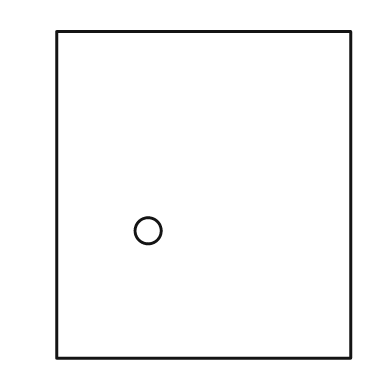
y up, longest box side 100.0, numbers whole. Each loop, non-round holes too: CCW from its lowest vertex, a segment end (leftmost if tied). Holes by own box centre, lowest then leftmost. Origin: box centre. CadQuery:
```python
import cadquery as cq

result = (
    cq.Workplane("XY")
    .moveTo(-45.0, -50.0)
    .lineTo(45.0, -50.0)
    .lineTo(45.0, 50.0)
    .lineTo(-45.0, 50.0)
    .close()
    .moveTo(-17.0, -11.0)
    .circle(4.0)
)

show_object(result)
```